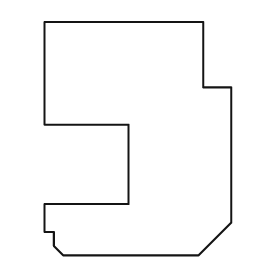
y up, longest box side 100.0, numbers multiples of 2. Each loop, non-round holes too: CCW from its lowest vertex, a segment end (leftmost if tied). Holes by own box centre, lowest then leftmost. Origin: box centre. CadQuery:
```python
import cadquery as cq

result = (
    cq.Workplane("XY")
    .moveTo(-32.0, -50.0)
    .lineTo(26.0, -50.0)
    .lineTo(40.0, -36.0)
    .lineTo(40.0, 22.0)
    .lineTo(28.0, 22.0)
    .lineTo(28.0, 50.0)
    .lineTo(-40.0, 50.0)
    .lineTo(-40.0, 6.0)
    .lineTo(-4.0, 6.0)
    .lineTo(-4.0, -28.0)
    .lineTo(-40.0, -28.0)
    .lineTo(-40.0, -40.0)
    .lineTo(-36.0, -40.0)
    .lineTo(-36.0, -46.0)
    .close()
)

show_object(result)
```